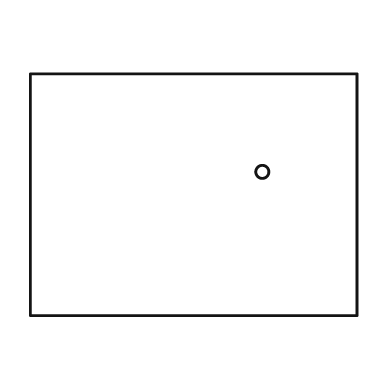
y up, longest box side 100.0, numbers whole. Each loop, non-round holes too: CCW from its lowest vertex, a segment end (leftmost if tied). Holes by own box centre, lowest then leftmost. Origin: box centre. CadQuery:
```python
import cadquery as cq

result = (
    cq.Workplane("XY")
    .moveTo(-50.0, -37.0)
    .lineTo(50.0, -37.0)
    .lineTo(50.0, 37.0)
    .lineTo(-50.0, 37.0)
    .close()
    .moveTo(21.0, 7.0)
    .circle(2.0)
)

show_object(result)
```